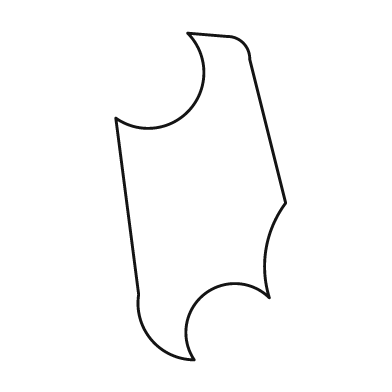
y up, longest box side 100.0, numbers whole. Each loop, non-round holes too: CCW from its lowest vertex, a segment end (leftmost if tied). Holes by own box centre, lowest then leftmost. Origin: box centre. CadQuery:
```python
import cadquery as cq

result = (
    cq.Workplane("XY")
    .moveTo(-2.0, -50.0)
    .threePointArc((1.0, -30.0), (21.0, -31.0))
    .threePointArc((20.0, -16.0), (26.0, -2.0))
    .lineTo(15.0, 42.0)
    .threePointArc((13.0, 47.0), (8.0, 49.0))
    .lineTo(-4.0, 50.0)
    .threePointArc((-3.0, 27.0), (-26.0, 24.0))
    .lineTo(-19.0, -30.0)
    .threePointArc((-15.0, -44.0), (-2.0, -50.0))
    .close()
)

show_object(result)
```